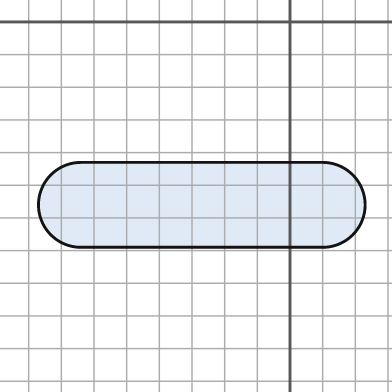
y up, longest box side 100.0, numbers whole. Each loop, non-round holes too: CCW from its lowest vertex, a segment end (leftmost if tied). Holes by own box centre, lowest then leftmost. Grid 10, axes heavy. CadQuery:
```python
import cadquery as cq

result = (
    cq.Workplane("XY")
    .moveTo(-64.0, -69.0)
    .lineTo(10.0, -69.0)
    .threePointArc((23.0, -56.0), (10.0, -43.0))
    .lineTo(-64.0, -43.0)
    .threePointArc((-77.0, -56.0), (-64.0, -69.0))
    .close()
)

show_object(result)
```